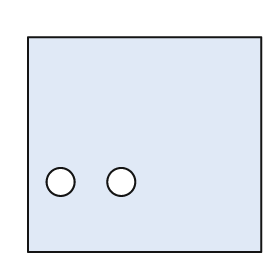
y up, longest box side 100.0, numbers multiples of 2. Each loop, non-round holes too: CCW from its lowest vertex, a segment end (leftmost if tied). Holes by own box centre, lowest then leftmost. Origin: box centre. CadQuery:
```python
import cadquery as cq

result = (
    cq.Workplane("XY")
    .moveTo(-50.0, -46.0)
    .lineTo(50.0, -46.0)
    .lineTo(50.0, 46.0)
    .lineTo(-50.0, 46.0)
    .close()
    .moveTo(-36.0, -16.0)
    .circle(6.0)
    .moveTo(-10.0, -16.0)
    .circle(6.0)
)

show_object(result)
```